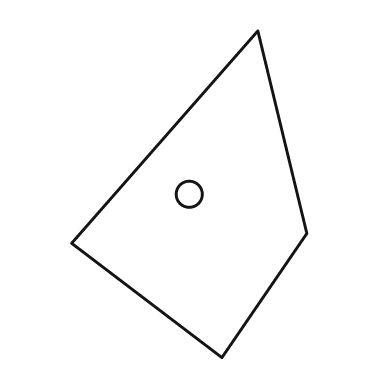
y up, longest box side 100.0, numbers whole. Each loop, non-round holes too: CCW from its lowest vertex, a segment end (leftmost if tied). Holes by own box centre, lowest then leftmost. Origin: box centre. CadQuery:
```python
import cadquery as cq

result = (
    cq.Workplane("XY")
    .moveTo(10.0, -50.0)
    .lineTo(36.0, -12.0)
    .lineTo(21.0, 50.0)
    .lineTo(-36.0, -15.0)
    .close()
    .moveTo(0.0, 0.0)
    .circle(4.0)
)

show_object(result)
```